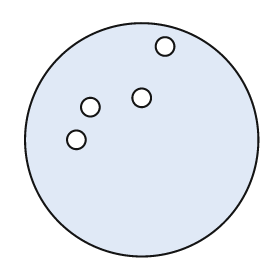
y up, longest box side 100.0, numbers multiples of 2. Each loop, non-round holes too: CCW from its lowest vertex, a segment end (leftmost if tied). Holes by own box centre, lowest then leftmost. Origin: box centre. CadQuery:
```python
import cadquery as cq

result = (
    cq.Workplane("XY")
    .moveTo(0.0, 0.0)
    .circle(50.0)
    .moveTo(-28.0, 0.0)
    .circle(4.0)
    .moveTo(-22.0, 14.0)
    .circle(4.0)
    .moveTo(0.0, 18.0)
    .circle(4.0)
    .moveTo(10.0, 40.0)
    .circle(4.0)
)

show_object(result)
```